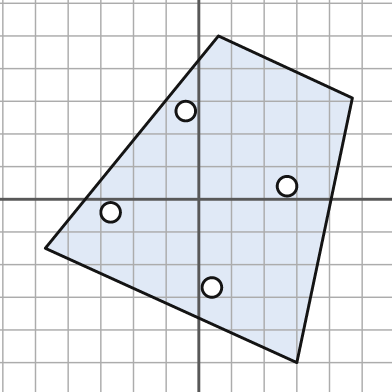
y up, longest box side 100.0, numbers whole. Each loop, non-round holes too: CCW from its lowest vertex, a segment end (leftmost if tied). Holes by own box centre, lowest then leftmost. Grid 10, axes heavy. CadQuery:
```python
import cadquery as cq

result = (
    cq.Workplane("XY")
    .moveTo(30.0, -50.0)
    .lineTo(47.0, 31.0)
    .lineTo(6.0, 50.0)
    .lineTo(-47.0, -15.0)
    .close()
    .moveTo(4.0, -27.0)
    .circle(3.0)
    .moveTo(-27.0, -4.0)
    .circle(3.0)
    .moveTo(27.0, 4.0)
    .circle(3.0)
    .moveTo(-4.0, 27.0)
    .circle(3.0)
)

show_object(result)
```